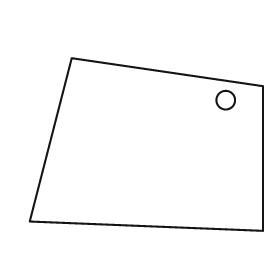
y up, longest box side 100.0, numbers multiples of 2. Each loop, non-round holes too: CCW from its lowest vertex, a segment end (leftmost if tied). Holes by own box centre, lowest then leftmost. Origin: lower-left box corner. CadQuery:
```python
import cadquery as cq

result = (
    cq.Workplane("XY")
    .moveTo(100.0, 0.0)
    .lineTo(100.0, 62.0)
    .lineTo(18.0, 74.0)
    .lineTo(0.0, 4.0)
    .close()
    .moveTo(84.0, 56.0)
    .circle(4.0)
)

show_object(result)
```